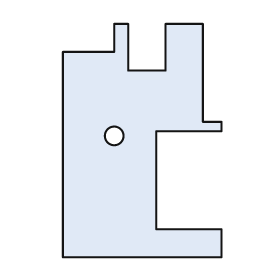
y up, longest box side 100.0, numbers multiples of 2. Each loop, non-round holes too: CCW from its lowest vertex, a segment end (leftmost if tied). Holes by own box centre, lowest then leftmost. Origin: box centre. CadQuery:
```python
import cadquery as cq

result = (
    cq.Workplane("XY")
    .moveTo(-34.0, -50.0)
    .lineTo(34.0, -50.0)
    .lineTo(34.0, -38.0)
    .lineTo(6.0, -38.0)
    .lineTo(6.0, 4.0)
    .lineTo(34.0, 4.0)
    .lineTo(34.0, 8.0)
    .lineTo(26.0, 8.0)
    .lineTo(26.0, 50.0)
    .lineTo(10.0, 50.0)
    .lineTo(10.0, 30.0)
    .lineTo(-6.0, 30.0)
    .lineTo(-6.0, 50.0)
    .lineTo(-12.0, 50.0)
    .lineTo(-12.0, 38.0)
    .lineTo(-34.0, 38.0)
    .close()
    .moveTo(-12.0, 2.0)
    .circle(4.0)
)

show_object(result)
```